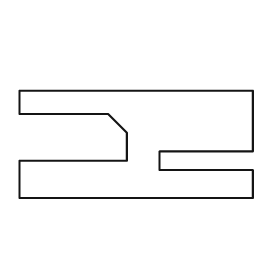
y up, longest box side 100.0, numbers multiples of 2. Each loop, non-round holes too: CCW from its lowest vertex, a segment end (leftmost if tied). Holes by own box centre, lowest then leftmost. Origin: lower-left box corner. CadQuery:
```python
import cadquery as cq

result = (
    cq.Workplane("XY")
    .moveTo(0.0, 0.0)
    .lineTo(100.0, 0.0)
    .lineTo(100.0, 12.0)
    .lineTo(60.0, 12.0)
    .lineTo(60.0, 20.0)
    .lineTo(100.0, 20.0)
    .lineTo(100.0, 46.0)
    .lineTo(0.0, 46.0)
    .lineTo(0.0, 36.0)
    .lineTo(38.0, 36.0)
    .lineTo(46.0, 28.0)
    .lineTo(46.0, 16.0)
    .lineTo(0.0, 16.0)
    .close()
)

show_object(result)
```